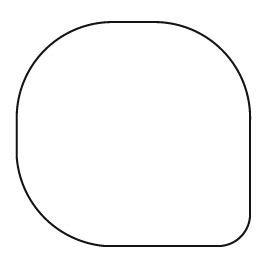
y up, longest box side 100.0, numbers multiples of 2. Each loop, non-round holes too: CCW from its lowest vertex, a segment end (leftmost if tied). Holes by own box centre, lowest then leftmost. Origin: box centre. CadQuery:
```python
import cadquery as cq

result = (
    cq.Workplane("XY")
    .moveTo(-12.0, -48.0)
    .lineTo(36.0, -48.0)
    .threePointArc((46.0, -44.0), (50.0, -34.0))
    .lineTo(50.0, 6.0)
    .threePointArc((38.0, 36.0), (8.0, 48.0))
    .lineTo(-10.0, 48.0)
    .threePointArc((-38.0, 36.0), (-50.0, 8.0))
    .lineTo(-50.0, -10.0)
    .threePointArc((-38.0, -36.0), (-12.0, -48.0))
    .close()
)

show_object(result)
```